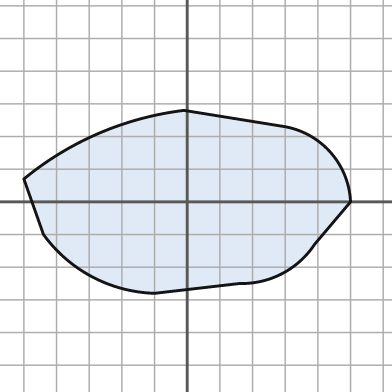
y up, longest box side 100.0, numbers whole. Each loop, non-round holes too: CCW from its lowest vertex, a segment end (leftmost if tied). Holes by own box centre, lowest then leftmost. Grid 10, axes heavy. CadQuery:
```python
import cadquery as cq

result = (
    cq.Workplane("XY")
    .moveTo(-10.0, -28.0)
    .lineTo(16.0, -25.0)
    .threePointArc((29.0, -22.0), (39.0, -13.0))
    .lineTo(50.0, 0.0)
    .threePointArc((44.0, 15.0), (30.0, 23.0))
    .lineTo(-1.0, 28.0)
    .threePointArc((-27.0, 21.0), (-50.0, 7.0))
    .lineTo(-44.0, -10.0)
    .threePointArc((-29.0, -23.0), (-10.0, -28.0))
    .close()
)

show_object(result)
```